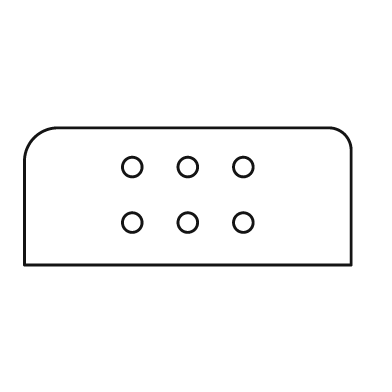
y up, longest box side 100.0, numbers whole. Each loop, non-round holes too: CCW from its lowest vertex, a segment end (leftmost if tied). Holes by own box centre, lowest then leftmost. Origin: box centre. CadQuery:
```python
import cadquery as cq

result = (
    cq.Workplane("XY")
    .moveTo(-50.0, -21.0)
    .lineTo(50.0, -21.0)
    .lineTo(50.0, 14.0)
    .threePointArc((48.0, 19.0), (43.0, 21.0))
    .lineTo(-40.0, 21.0)
    .threePointArc((-47.0, 18.0), (-50.0, 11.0))
    .close()
    .moveTo(-17.0, -8.0)
    .circle(3.0)
    .moveTo(0.0, -8.0)
    .circle(3.0)
    .moveTo(17.0, -8.0)
    .circle(3.0)
    .moveTo(-17.0, 9.0)
    .circle(3.0)
    .moveTo(0.0, 9.0)
    .circle(3.0)
    .moveTo(17.0, 9.0)
    .circle(3.0)
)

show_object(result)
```